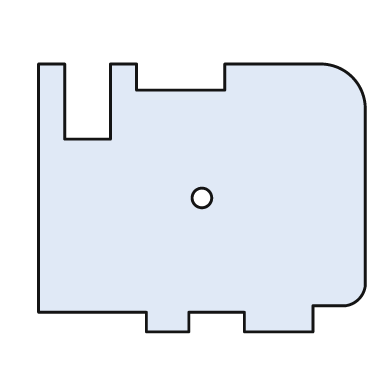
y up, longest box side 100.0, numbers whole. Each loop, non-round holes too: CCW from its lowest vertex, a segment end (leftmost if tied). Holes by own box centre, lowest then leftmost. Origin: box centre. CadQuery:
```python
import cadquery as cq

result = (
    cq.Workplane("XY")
    .moveTo(-17.0, -41.0)
    .lineTo(-4.0, -41.0)
    .lineTo(-4.0, -35.0)
    .lineTo(13.0, -35.0)
    .lineTo(13.0, -41.0)
    .lineTo(34.0, -41.0)
    .lineTo(34.0, -33.0)
    .lineTo(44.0, -33.0)
    .threePointArc((48.0, -31.0), (50.0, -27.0))
    .lineTo(50.0, 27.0)
    .threePointArc((46.0, 37.0), (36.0, 41.0))
    .lineTo(7.0, 41.0)
    .lineTo(7.0, 33.0)
    .lineTo(-20.0, 33.0)
    .lineTo(-20.0, 41.0)
    .lineTo(-28.0, 41.0)
    .lineTo(-28.0, 18.0)
    .lineTo(-42.0, 18.0)
    .lineTo(-42.0, 41.0)
    .lineTo(-50.0, 41.0)
    .lineTo(-50.0, -35.0)
    .lineTo(-17.0, -35.0)
    .close()
    .moveTo(0.0, 0.0)
    .circle(3.0)
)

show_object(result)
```